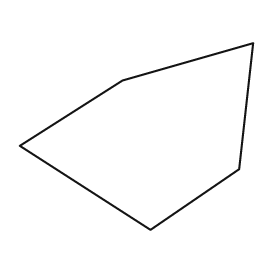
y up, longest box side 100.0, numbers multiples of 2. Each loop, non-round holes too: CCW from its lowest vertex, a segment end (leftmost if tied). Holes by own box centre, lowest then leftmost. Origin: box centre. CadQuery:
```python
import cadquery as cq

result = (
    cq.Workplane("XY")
    .moveTo(6.0, -40.0)
    .lineTo(44.0, -14.0)
    .lineTo(50.0, 40.0)
    .lineTo(-6.0, 24.0)
    .lineTo(-50.0, -4.0)
    .close()
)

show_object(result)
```